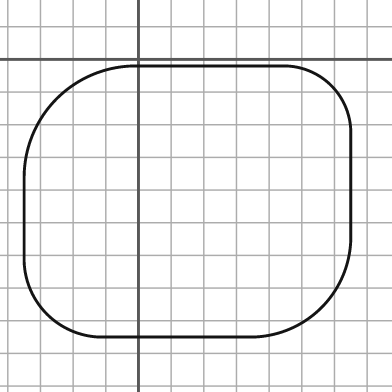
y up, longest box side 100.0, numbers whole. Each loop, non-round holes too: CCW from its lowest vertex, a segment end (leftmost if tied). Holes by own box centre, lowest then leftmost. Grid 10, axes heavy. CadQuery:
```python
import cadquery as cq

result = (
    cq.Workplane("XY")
    .moveTo(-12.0, -85.0)
    .lineTo(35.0, -85.0)
    .threePointArc((56.0, -76.0), (65.0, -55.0))
    .lineTo(65.0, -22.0)
    .threePointArc((59.0, -8.0), (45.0, -2.0))
    .lineTo(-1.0, -2.0)
    .threePointArc((-25.0, -12.0), (-35.0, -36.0))
    .lineTo(-35.0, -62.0)
    .threePointArc((-28.0, -78.0), (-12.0, -85.0))
    .close()
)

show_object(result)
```